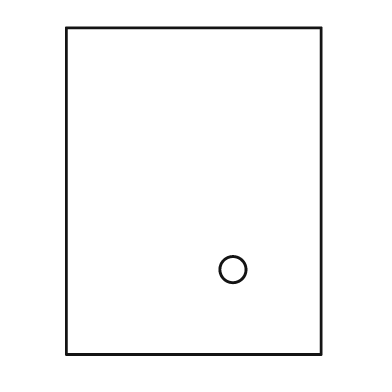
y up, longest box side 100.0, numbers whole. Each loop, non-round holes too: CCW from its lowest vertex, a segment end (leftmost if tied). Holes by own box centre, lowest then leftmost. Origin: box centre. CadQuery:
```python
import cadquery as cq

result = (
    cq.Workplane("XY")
    .moveTo(-39.0, -50.0)
    .lineTo(39.0, -50.0)
    .lineTo(39.0, 50.0)
    .lineTo(-39.0, 50.0)
    .close()
    .moveTo(12.0, -24.0)
    .circle(4.0)
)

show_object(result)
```